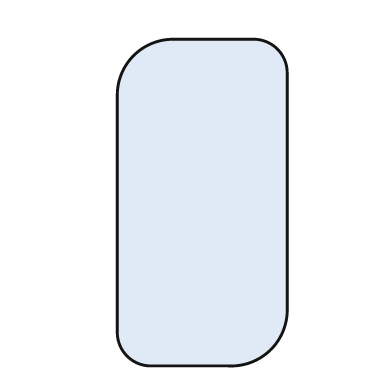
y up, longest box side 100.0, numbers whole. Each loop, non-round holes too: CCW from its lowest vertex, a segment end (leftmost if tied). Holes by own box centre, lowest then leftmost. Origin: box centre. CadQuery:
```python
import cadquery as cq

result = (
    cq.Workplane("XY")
    .moveTo(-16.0, -50.0)
    .lineTo(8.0, -50.0)
    .threePointArc((21.0, -45.0), (26.0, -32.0))
    .lineTo(26.0, 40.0)
    .threePointArc((23.0, 47.0), (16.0, 50.0))
    .lineTo(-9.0, 50.0)
    .threePointArc((-21.0, 45.0), (-26.0, 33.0))
    .lineTo(-26.0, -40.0)
    .threePointArc((-23.0, -47.0), (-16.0, -50.0))
    .close()
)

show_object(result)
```